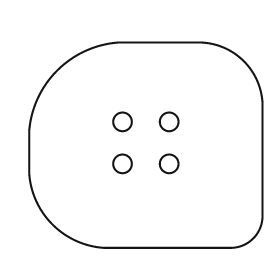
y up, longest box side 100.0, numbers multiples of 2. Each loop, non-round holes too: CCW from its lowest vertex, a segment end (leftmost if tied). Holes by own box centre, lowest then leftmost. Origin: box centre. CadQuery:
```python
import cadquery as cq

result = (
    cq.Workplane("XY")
    .moveTo(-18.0, -44.0)
    .lineTo(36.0, -44.0)
    .threePointArc((46.0, -40.0), (50.0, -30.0))
    .lineTo(50.0, 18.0)
    .threePointArc((42.0, 36.0), (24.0, 44.0))
    .lineTo(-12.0, 44.0)
    .threePointArc((-38.0, 32.0), (-50.0, 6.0))
    .lineTo(-50.0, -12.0)
    .threePointArc((-40.0, -34.0), (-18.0, -44.0))
    .close()
    .moveTo(-10.0, -8.0)
    .circle(4.0)
    .moveTo(10.0, -8.0)
    .circle(4.0)
    .moveTo(-10.0, 10.0)
    .circle(4.0)
    .moveTo(10.0, 10.0)
    .circle(4.0)
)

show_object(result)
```